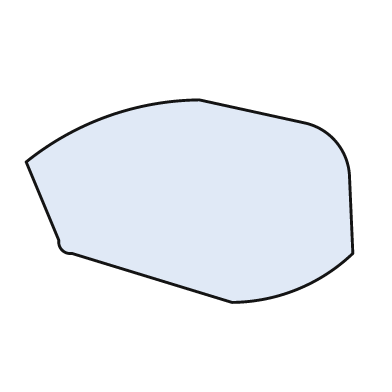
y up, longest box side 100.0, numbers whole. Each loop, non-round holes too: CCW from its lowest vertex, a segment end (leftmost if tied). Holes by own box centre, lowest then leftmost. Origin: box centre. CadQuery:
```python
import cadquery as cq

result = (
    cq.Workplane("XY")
    .moveTo(13.0, -31.0)
    .threePointArc((33.0, -27.0), (50.0, -16.0))
    .lineTo(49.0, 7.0)
    .threePointArc((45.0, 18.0), (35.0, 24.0))
    .lineTo(3.0, 31.0)
    .threePointArc((-25.0, 26.0), (-50.0, 12.0))
    .lineTo(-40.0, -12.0)
    .threePointArc((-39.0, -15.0), (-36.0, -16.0))
    .close()
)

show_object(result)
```